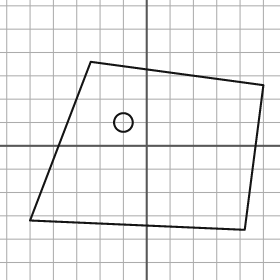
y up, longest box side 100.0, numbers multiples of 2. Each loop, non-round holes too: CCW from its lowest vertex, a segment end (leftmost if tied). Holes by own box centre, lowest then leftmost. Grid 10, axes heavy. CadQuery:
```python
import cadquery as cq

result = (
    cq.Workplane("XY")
    .moveTo(42.0, -36.0)
    .lineTo(50.0, 26.0)
    .lineTo(-24.0, 36.0)
    .lineTo(-50.0, -32.0)
    .close()
    .moveTo(-10.0, 10.0)
    .circle(4.0)
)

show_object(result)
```